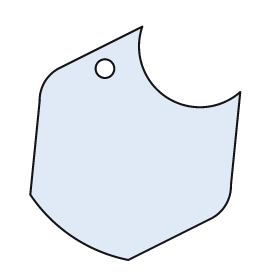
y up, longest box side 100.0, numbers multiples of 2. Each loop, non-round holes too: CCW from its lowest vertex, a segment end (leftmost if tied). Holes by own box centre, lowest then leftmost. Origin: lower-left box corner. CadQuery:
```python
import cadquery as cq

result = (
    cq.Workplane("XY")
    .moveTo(42.0, 0.0)
    .lineTo(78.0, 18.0)
    .threePointArc((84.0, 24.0), (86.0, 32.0))
    .lineTo(90.0, 72.0)
    .threePointArc((58.0, 70.0), (48.0, 100.0))
    .lineTo(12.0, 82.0)
    .threePointArc((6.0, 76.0), (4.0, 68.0))
    .lineTo(0.0, 28.0)
    .threePointArc((18.0, 10.0), (42.0, 0.0))
    .close()
    .moveTo(32.0, 82.0)
    .circle(4.0)
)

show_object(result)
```